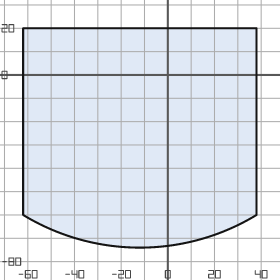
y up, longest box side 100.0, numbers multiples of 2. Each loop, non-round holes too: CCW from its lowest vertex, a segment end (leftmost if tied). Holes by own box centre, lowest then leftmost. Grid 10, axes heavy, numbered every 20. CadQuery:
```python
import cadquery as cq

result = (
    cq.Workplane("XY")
    .moveTo(-62.0, -60.0)
    .threePointArc((-12.0, -74.0), (38.0, -60.0))
    .lineTo(38.0, 20.0)
    .lineTo(-62.0, 20.0)
    .close()
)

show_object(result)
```